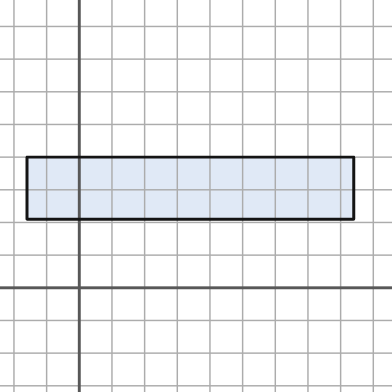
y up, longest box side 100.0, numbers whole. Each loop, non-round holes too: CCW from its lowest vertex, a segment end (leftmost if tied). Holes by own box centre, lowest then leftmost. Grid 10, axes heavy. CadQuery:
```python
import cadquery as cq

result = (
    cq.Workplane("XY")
    .moveTo(-16.0, 21.0)
    .lineTo(84.0, 21.0)
    .lineTo(84.0, 40.0)
    .lineTo(-16.0, 40.0)
    .close()
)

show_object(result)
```